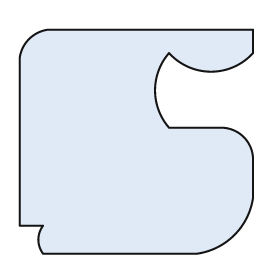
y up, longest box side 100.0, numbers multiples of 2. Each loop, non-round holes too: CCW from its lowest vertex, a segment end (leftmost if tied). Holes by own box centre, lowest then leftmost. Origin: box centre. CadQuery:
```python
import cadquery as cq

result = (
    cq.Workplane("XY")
    .moveTo(-40.0, -48.0)
    .lineTo(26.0, -48.0)
    .threePointArc((42.0, -40.0), (50.0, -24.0))
    .lineTo(50.0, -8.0)
    .threePointArc((46.0, 2.0), (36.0, 6.0))
    .lineTo(14.0, 6.0)
    .threePointArc((8.0, 22.0), (14.0, 38.0))
    .threePointArc((32.0, 30.0), (50.0, 38.0))
    .lineTo(50.0, 48.0)
    .lineTo(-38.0, 48.0)
    .threePointArc((-46.0, 44.0), (-50.0, 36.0))
    .lineTo(-50.0, -36.0)
    .lineTo(-40.0, -36.0)
    .threePointArc((-42.0, -42.0), (-40.0, -48.0))
    .close()
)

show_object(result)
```